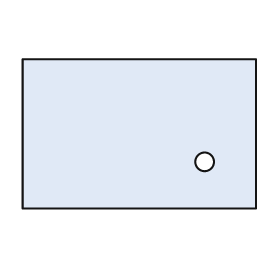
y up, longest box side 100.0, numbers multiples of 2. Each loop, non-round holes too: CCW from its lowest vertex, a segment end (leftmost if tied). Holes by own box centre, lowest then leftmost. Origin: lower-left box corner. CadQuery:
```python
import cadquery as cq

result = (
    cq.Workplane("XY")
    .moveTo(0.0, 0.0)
    .lineTo(100.0, 0.0)
    .lineTo(100.0, 64.0)
    .lineTo(0.0, 64.0)
    .close()
    .moveTo(78.0, 20.0)
    .circle(4.0)
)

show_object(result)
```